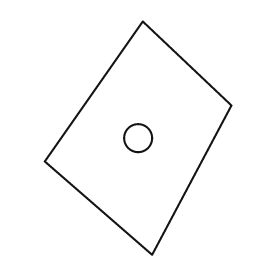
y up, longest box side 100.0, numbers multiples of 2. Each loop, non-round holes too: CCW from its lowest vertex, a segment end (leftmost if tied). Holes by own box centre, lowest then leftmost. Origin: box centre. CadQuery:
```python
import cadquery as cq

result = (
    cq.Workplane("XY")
    .moveTo(6.0, -50.0)
    .lineTo(40.0, 14.0)
    .lineTo(2.0, 50.0)
    .lineTo(-40.0, -10.0)
    .close()
    .moveTo(0.0, 0.0)
    .circle(6.0)
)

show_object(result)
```